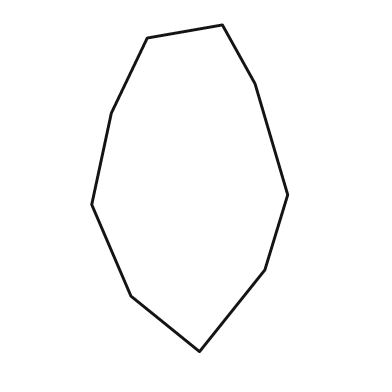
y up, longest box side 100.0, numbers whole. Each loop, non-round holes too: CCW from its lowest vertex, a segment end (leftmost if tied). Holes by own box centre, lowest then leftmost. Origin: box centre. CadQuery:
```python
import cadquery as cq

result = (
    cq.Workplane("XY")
    .moveTo(3.0, -50.0)
    .lineTo(23.0, -25.0)
    .lineTo(30.0, -2.0)
    .lineTo(20.0, 32.0)
    .lineTo(10.0, 50.0)
    .lineTo(-13.0, 46.0)
    .lineTo(-24.0, 23.0)
    .lineTo(-30.0, -5.0)
    .lineTo(-18.0, -33.0)
    .close()
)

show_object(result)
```